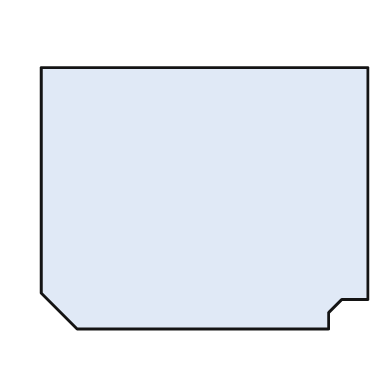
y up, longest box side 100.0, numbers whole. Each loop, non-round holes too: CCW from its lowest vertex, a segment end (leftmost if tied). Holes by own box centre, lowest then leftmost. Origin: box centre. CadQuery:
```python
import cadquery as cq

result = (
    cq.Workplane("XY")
    .moveTo(-39.0, -40.0)
    .lineTo(38.0, -40.0)
    .lineTo(38.0, -35.0)
    .lineTo(42.0, -31.0)
    .lineTo(50.0, -31.0)
    .lineTo(50.0, 40.0)
    .lineTo(-50.0, 40.0)
    .lineTo(-50.0, -29.0)
    .close()
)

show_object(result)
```